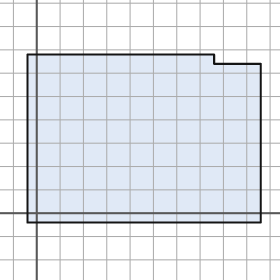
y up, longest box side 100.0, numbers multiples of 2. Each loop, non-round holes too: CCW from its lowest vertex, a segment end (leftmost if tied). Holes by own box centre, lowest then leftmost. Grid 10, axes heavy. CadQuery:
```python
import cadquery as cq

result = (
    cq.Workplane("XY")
    .moveTo(-4.0, -4.0)
    .lineTo(96.0, -4.0)
    .lineTo(96.0, 64.0)
    .lineTo(76.0, 64.0)
    .lineTo(76.0, 68.0)
    .lineTo(-4.0, 68.0)
    .close()
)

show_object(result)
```